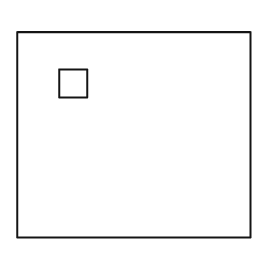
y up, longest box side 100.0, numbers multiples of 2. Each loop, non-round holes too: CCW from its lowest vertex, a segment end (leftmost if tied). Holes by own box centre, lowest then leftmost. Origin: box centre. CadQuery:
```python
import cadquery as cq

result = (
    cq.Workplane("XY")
    .moveTo(-50.0, -44.0)
    .lineTo(50.0, -44.0)
    .lineTo(50.0, 44.0)
    .lineTo(-50.0, 44.0)
    .close()
    .moveTo(-32.0, 16.0)
    .lineTo(-20.0, 16.0)
    .lineTo(-20.0, 28.0)
    .lineTo(-32.0, 28.0)
    .close()
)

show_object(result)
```